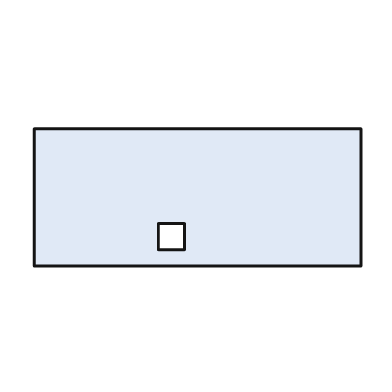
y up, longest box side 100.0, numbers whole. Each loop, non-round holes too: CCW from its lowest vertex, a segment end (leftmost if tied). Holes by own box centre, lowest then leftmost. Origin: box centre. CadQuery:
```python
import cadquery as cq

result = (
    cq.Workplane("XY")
    .moveTo(-50.0, -21.0)
    .lineTo(50.0, -21.0)
    .lineTo(50.0, 21.0)
    .lineTo(-50.0, 21.0)
    .close()
    .moveTo(-12.0, -16.0)
    .lineTo(-4.0, -16.0)
    .lineTo(-4.0, -8.0)
    .lineTo(-12.0, -8.0)
    .close()
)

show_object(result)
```